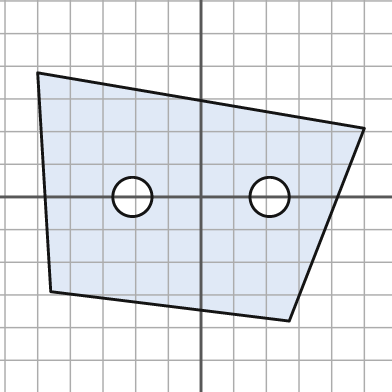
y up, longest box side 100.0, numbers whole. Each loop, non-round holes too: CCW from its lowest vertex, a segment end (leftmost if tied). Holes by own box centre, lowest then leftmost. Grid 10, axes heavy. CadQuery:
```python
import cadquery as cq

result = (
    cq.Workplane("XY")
    .moveTo(27.0, -38.0)
    .lineTo(50.0, 21.0)
    .lineTo(-50.0, 38.0)
    .lineTo(-46.0, -29.0)
    .close()
    .moveTo(-21.0, 0.0)
    .circle(6.0)
    .moveTo(21.0, 0.0)
    .circle(6.0)
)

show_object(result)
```